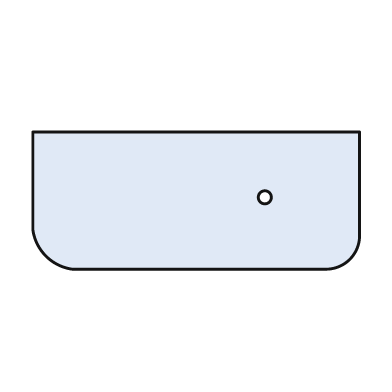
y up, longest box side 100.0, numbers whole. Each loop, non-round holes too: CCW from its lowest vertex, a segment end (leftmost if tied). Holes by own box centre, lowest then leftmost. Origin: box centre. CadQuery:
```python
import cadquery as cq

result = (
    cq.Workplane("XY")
    .moveTo(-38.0, -21.0)
    .lineTo(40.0, -21.0)
    .threePointArc((47.0, -18.0), (50.0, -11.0))
    .lineTo(50.0, 21.0)
    .lineTo(-50.0, 21.0)
    .lineTo(-50.0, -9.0)
    .threePointArc((-46.0, -17.0), (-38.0, -21.0))
    .close()
    .moveTo(21.0, 1.0)
    .circle(2.0)
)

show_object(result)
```